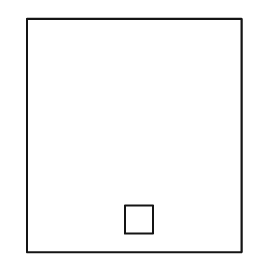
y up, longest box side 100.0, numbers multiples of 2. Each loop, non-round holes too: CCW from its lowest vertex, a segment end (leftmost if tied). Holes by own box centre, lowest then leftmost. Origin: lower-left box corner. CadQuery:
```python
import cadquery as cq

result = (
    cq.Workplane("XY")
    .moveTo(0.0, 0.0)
    .lineTo(92.0, 0.0)
    .lineTo(92.0, 100.0)
    .lineTo(0.0, 100.0)
    .close()
    .moveTo(42.0, 8.0)
    .lineTo(54.0, 8.0)
    .lineTo(54.0, 20.0)
    .lineTo(42.0, 20.0)
    .close()
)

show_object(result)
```